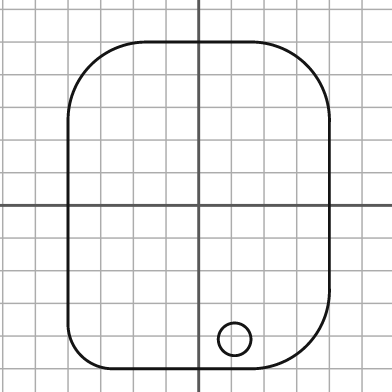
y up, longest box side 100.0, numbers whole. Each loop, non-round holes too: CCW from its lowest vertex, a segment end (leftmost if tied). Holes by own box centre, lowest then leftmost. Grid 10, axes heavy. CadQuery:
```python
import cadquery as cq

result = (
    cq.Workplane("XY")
    .moveTo(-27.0, -50.0)
    .lineTo(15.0, -50.0)
    .threePointArc((33.0, -43.0), (40.0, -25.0))
    .lineTo(40.0, 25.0)
    .threePointArc((33.0, 43.0), (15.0, 50.0))
    .lineTo(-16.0, 50.0)
    .threePointArc((-33.0, 43.0), (-40.0, 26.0))
    .lineTo(-40.0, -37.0)
    .threePointArc((-36.0, -46.0), (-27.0, -50.0))
    .close()
    .moveTo(11.0, -41.0)
    .circle(5.0)
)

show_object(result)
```